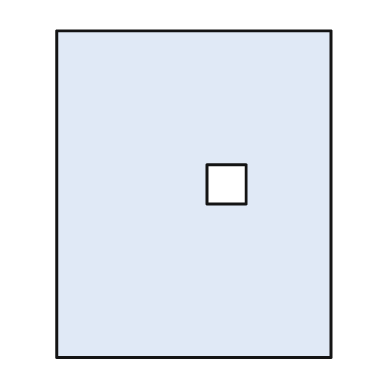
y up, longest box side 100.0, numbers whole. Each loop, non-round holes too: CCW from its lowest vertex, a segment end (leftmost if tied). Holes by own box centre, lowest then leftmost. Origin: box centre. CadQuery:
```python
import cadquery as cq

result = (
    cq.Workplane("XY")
    .moveTo(-42.0, -50.0)
    .lineTo(42.0, -50.0)
    .lineTo(42.0, 50.0)
    .lineTo(-42.0, 50.0)
    .close()
    .moveTo(4.0, -3.0)
    .lineTo(16.0, -3.0)
    .lineTo(16.0, 9.0)
    .lineTo(4.0, 9.0)
    .close()
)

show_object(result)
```